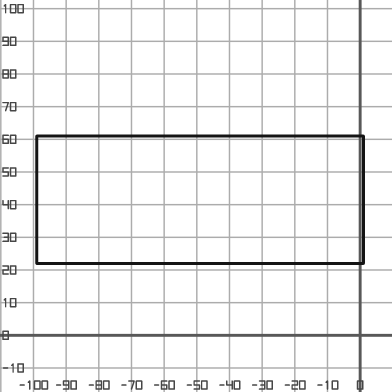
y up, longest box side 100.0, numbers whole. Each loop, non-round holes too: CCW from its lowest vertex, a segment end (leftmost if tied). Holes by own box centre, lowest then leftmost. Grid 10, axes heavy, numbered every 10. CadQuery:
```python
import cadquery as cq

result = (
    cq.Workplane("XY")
    .moveTo(-99.0, 22.0)
    .lineTo(1.0, 22.0)
    .lineTo(1.0, 61.0)
    .lineTo(-99.0, 61.0)
    .close()
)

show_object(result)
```